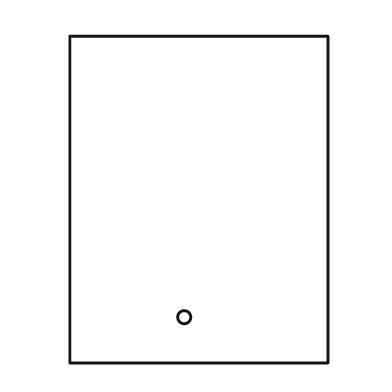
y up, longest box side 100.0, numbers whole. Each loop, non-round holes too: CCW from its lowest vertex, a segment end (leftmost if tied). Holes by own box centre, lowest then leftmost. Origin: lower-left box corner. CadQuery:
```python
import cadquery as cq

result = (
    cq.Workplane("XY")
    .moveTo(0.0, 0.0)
    .lineTo(79.0, 0.0)
    .lineTo(79.0, 100.0)
    .lineTo(0.0, 100.0)
    .close()
    .moveTo(35.0, 14.0)
    .circle(2.0)
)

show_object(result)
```